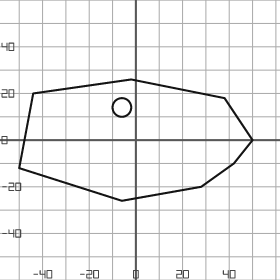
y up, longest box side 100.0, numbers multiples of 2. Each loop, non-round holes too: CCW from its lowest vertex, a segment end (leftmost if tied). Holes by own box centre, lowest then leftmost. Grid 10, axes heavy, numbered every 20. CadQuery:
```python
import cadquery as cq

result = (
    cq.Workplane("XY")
    .moveTo(-6.0, -26.0)
    .lineTo(28.0, -20.0)
    .lineTo(42.0, -10.0)
    .lineTo(50.0, 0.0)
    .lineTo(38.0, 18.0)
    .lineTo(-2.0, 26.0)
    .lineTo(-44.0, 20.0)
    .lineTo(-50.0, -12.0)
    .close()
    .moveTo(-6.0, 14.0)
    .circle(4.0)
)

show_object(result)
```